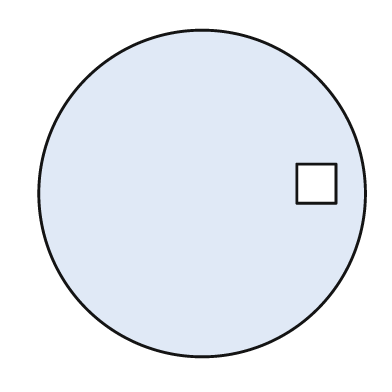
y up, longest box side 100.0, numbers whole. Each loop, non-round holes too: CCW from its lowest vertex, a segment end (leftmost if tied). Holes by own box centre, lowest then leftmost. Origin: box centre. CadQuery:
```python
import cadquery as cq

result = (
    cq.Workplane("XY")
    .moveTo(0.0, 0.0)
    .circle(50.0)
    .moveTo(29.0, -3.0)
    .lineTo(41.0, -3.0)
    .lineTo(41.0, 9.0)
    .lineTo(29.0, 9.0)
    .close()
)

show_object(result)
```